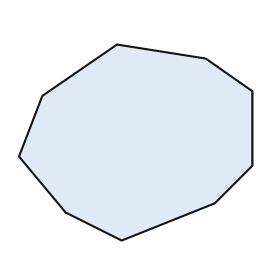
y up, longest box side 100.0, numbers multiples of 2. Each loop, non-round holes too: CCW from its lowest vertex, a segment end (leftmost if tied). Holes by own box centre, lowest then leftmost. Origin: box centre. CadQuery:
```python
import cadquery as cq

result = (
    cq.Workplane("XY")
    .moveTo(-6.0, -42.0)
    .lineTo(34.0, -26.0)
    .lineTo(50.0, -10.0)
    .lineTo(50.0, 22.0)
    .lineTo(30.0, 36.0)
    .lineTo(-8.0, 42.0)
    .lineTo(-40.0, 20.0)
    .lineTo(-50.0, -6.0)
    .lineTo(-30.0, -30.0)
    .close()
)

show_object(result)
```